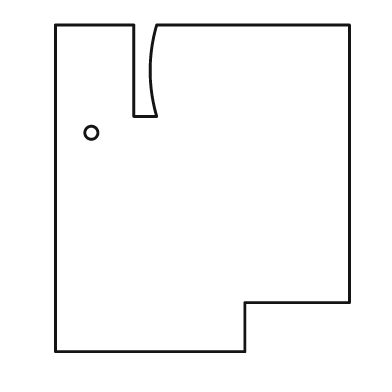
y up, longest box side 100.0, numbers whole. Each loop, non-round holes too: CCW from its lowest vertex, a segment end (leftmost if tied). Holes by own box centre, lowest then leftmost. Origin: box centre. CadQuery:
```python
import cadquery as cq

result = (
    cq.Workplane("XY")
    .moveTo(-45.0, -50.0)
    .lineTo(13.0, -50.0)
    .lineTo(13.0, -35.0)
    .lineTo(45.0, -35.0)
    .lineTo(45.0, 50.0)
    .lineTo(-14.0, 50.0)
    .threePointArc((-16.0, 36.0), (-14.0, 22.0))
    .lineTo(-21.0, 22.0)
    .lineTo(-21.0, 50.0)
    .lineTo(-45.0, 50.0)
    .close()
    .moveTo(-34.0, 17.0)
    .circle(2.0)
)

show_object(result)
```